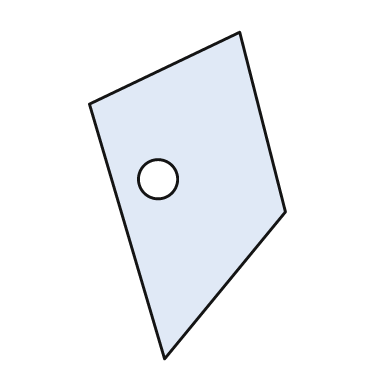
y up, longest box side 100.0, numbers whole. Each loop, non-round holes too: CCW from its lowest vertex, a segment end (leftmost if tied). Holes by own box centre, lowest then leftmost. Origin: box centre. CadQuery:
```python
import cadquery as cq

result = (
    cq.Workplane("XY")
    .moveTo(-7.0, -50.0)
    .lineTo(30.0, -5.0)
    .lineTo(16.0, 50.0)
    .lineTo(-30.0, 28.0)
    .close()
    .moveTo(-9.0, 5.0)
    .circle(6.0)
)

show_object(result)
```